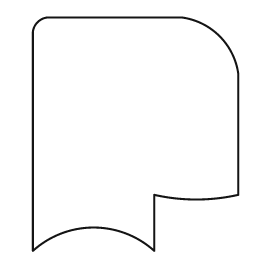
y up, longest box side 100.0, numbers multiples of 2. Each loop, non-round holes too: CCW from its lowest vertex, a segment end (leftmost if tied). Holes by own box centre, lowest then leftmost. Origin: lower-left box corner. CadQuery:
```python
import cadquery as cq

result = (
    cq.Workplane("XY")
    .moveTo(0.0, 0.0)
    .threePointArc((26.0, 10.0), (52.0, 0.0))
    .lineTo(52.0, 24.0)
    .threePointArc((70.0, 22.0), (88.0, 24.0))
    .lineTo(88.0, 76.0)
    .threePointArc((80.0, 92.0), (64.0, 100.0))
    .lineTo(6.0, 100.0)
    .threePointArc((2.0, 98.0), (0.0, 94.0))
    .close()
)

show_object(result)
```